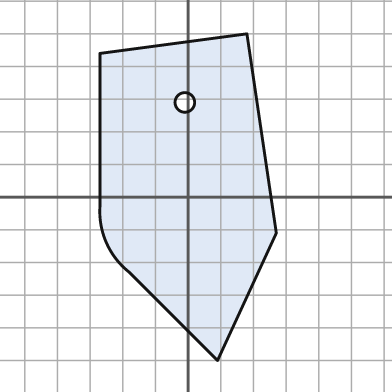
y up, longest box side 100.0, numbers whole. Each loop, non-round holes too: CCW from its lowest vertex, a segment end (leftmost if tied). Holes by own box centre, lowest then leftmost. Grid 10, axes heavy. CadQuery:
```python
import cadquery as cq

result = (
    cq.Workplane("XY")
    .moveTo(9.0, -50.0)
    .lineTo(27.0, -11.0)
    .lineTo(18.0, 50.0)
    .lineTo(-27.0, 44.0)
    .lineTo(-27.0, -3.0)
    .threePointArc((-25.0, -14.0), (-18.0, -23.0))
    .close()
    .moveTo(-1.0, 29.0)
    .circle(3.0)
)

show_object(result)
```